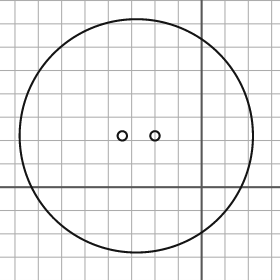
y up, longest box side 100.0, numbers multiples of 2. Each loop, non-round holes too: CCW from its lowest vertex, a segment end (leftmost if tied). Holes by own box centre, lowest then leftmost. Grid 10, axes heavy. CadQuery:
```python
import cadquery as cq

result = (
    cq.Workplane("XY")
    .moveTo(-28.0, 22.0)
    .circle(50.0)
    .moveTo(-34.0, 22.0)
    .circle(2.0)
    .moveTo(-20.0, 22.0)
    .circle(2.0)
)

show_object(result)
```